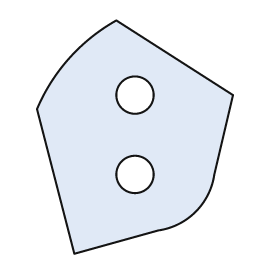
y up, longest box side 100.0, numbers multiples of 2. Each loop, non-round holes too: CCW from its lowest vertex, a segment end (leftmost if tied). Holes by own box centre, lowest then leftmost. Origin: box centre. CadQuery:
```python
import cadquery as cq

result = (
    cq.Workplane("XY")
    .moveTo(-26.0, -50.0)
    .lineTo(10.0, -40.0)
    .threePointArc((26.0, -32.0), (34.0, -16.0))
    .lineTo(42.0, 18.0)
    .lineTo(-8.0, 50.0)
    .threePointArc((-28.0, 34.0), (-42.0, 12.0))
    .close()
    .moveTo(0.0, -16.0)
    .circle(8.0)
    .moveTo(0.0, 18.0)
    .circle(8.0)
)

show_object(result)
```